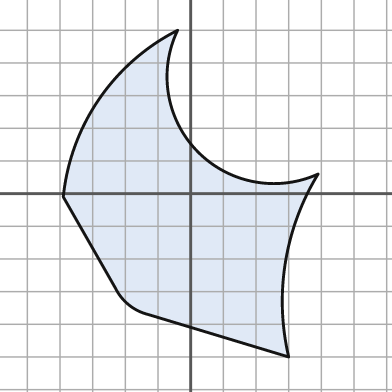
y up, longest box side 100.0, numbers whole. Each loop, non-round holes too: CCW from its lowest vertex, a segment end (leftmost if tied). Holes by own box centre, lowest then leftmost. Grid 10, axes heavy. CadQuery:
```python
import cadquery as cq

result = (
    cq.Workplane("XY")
    .moveTo(30.0, -50.0)
    .threePointArc((29.0, -21.0), (39.0, 6.0))
    .threePointArc((2.0, 13.0), (-4.0, 50.0))
    .threePointArc((-28.0, 29.0), (-39.0, -1.0))
    .lineTo(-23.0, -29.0)
    .threePointArc((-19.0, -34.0), (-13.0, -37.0))
    .close()
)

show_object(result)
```